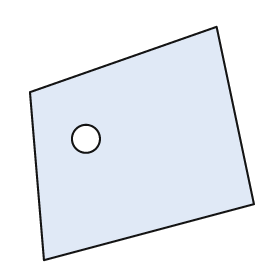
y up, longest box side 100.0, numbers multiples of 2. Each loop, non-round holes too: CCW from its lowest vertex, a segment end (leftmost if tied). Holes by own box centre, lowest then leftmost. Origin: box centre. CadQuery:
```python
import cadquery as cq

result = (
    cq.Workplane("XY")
    .moveTo(-42.0, -50.0)
    .lineTo(48.0, -26.0)
    .lineTo(32.0, 50.0)
    .lineTo(-48.0, 22.0)
    .close()
    .moveTo(-24.0, 2.0)
    .circle(6.0)
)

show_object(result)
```